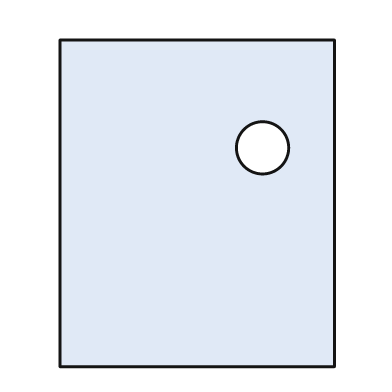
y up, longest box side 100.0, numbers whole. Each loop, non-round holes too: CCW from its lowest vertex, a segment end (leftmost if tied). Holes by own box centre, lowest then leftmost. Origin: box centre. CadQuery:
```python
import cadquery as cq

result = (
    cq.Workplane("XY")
    .moveTo(-42.0, -50.0)
    .lineTo(42.0, -50.0)
    .lineTo(42.0, 50.0)
    .lineTo(-42.0, 50.0)
    .close()
    .moveTo(20.0, 17.0)
    .circle(8.0)
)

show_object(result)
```